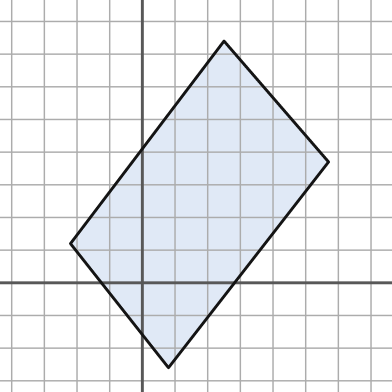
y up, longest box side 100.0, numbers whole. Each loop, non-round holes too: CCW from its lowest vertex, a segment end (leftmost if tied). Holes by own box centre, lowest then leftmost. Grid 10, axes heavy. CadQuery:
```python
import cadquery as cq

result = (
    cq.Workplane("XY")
    .moveTo(8.0, -26.0)
    .lineTo(57.0, 37.0)
    .lineTo(25.0, 74.0)
    .lineTo(-22.0, 12.0)
    .close()
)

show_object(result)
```